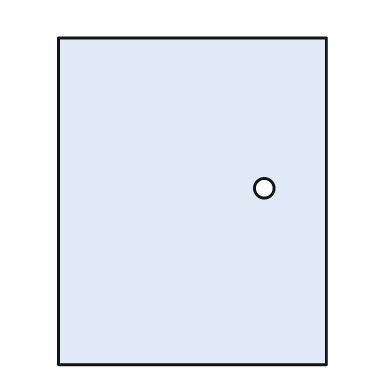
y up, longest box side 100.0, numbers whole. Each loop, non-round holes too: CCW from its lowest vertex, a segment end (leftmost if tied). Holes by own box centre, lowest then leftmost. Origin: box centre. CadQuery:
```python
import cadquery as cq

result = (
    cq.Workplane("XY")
    .moveTo(-41.0, -50.0)
    .lineTo(41.0, -50.0)
    .lineTo(41.0, 50.0)
    .lineTo(-41.0, 50.0)
    .close()
    .moveTo(22.0, 4.0)
    .circle(3.0)
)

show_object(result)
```